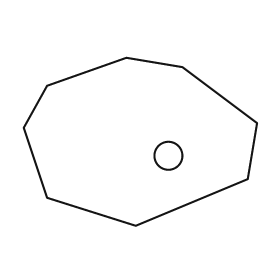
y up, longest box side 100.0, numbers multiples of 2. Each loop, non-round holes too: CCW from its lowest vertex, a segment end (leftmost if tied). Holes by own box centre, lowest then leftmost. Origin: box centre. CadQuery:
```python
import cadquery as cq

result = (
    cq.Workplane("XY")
    .moveTo(-2.0, -36.0)
    .lineTo(46.0, -16.0)
    .lineTo(50.0, 8.0)
    .lineTo(18.0, 32.0)
    .lineTo(-6.0, 36.0)
    .lineTo(-40.0, 24.0)
    .lineTo(-50.0, 6.0)
    .lineTo(-40.0, -24.0)
    .close()
    .moveTo(12.0, -6.0)
    .circle(6.0)
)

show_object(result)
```